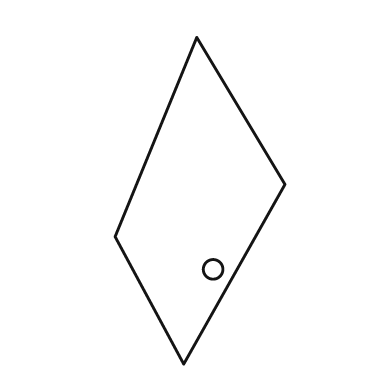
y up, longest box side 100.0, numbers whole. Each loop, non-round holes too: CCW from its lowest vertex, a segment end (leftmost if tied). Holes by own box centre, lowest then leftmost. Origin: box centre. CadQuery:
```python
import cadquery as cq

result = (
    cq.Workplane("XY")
    .moveTo(-5.0, -50.0)
    .lineTo(26.0, 5.0)
    .lineTo(-1.0, 50.0)
    .lineTo(-26.0, -11.0)
    .close()
    .moveTo(4.0, -21.0)
    .circle(3.0)
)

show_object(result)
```